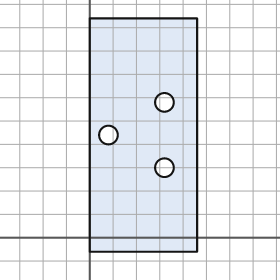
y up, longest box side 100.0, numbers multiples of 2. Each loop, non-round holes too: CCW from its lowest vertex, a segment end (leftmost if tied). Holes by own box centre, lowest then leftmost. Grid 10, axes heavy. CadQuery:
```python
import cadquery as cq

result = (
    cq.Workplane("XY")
    .moveTo(0.0, -6.0)
    .lineTo(46.0, -6.0)
    .lineTo(46.0, 94.0)
    .lineTo(0.0, 94.0)
    .close()
    .moveTo(32.0, 30.0)
    .circle(4.0)
    .moveTo(8.0, 44.0)
    .circle(4.0)
    .moveTo(32.0, 58.0)
    .circle(4.0)
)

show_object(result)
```